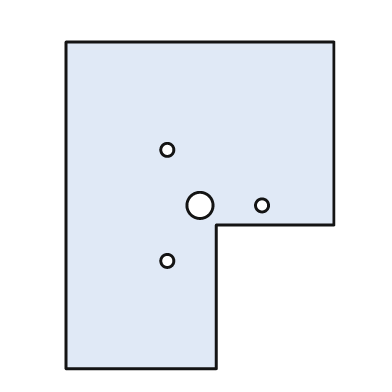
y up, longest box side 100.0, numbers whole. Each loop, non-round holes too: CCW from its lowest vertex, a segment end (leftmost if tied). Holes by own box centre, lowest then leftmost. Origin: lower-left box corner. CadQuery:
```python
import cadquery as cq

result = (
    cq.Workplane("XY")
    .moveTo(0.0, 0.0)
    .lineTo(46.0, 0.0)
    .lineTo(46.0, 44.0)
    .lineTo(82.0, 44.0)
    .lineTo(82.0, 100.0)
    .lineTo(0.0, 100.0)
    .close()
    .moveTo(31.0, 33.0)
    .circle(2.0)
    .moveTo(41.0, 50.0)
    .circle(4.0)
    .moveTo(60.0, 50.0)
    .circle(2.0)
    .moveTo(31.0, 67.0)
    .circle(2.0)
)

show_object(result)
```